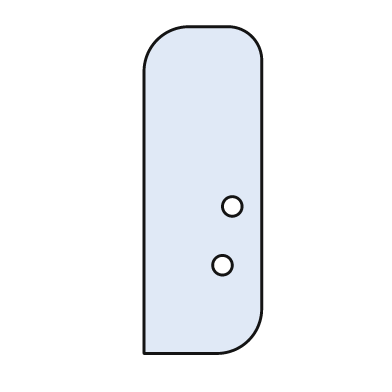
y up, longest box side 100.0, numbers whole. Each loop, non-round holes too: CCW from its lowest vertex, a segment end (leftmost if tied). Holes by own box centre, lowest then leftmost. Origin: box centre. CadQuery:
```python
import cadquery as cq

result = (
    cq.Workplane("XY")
    .moveTo(-18.0, -50.0)
    .lineTo(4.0, -50.0)
    .threePointArc((14.0, -46.0), (18.0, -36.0))
    .lineTo(18.0, 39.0)
    .threePointArc((15.0, 47.0), (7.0, 50.0))
    .lineTo(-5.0, 50.0)
    .threePointArc((-14.0, 46.0), (-18.0, 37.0))
    .close()
    .moveTo(6.0, -23.0)
    .circle(3.0)
    .moveTo(9.0, -5.0)
    .circle(3.0)
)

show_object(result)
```